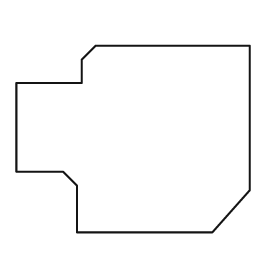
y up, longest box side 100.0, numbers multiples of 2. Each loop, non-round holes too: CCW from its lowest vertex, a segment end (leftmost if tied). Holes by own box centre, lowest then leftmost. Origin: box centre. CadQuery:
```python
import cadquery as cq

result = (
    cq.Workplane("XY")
    .moveTo(-24.0, -40.0)
    .lineTo(34.0, -40.0)
    .lineTo(50.0, -22.0)
    .lineTo(50.0, 40.0)
    .lineTo(-16.0, 40.0)
    .lineTo(-22.0, 34.0)
    .lineTo(-22.0, 24.0)
    .lineTo(-50.0, 24.0)
    .lineTo(-50.0, -14.0)
    .lineTo(-30.0, -14.0)
    .lineTo(-24.0, -20.0)
    .close()
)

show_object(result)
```